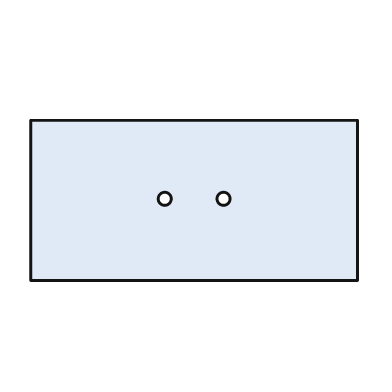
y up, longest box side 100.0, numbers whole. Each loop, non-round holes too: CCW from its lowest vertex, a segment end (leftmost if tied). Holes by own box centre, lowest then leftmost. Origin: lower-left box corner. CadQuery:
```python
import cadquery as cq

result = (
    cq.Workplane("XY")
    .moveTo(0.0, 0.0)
    .lineTo(100.0, 0.0)
    .lineTo(100.0, 49.0)
    .lineTo(0.0, 49.0)
    .close()
    .moveTo(41.0, 25.0)
    .circle(2.0)
    .moveTo(59.0, 25.0)
    .circle(2.0)
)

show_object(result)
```